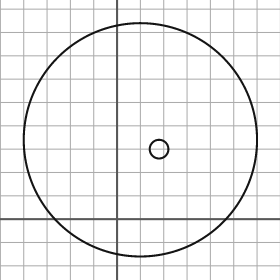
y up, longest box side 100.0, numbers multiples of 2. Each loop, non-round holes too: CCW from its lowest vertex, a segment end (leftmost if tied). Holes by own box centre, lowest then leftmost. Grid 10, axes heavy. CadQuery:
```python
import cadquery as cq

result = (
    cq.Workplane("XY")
    .moveTo(10.0, 34.0)
    .circle(50.0)
    .moveTo(18.0, 30.0)
    .circle(4.0)
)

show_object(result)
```